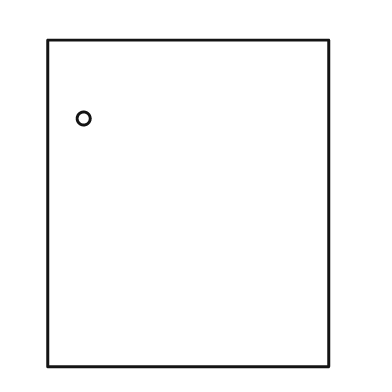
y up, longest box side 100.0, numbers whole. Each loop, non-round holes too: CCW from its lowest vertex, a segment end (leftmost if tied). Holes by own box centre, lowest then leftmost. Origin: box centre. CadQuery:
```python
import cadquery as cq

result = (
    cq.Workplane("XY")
    .moveTo(-43.0, -50.0)
    .lineTo(43.0, -50.0)
    .lineTo(43.0, 50.0)
    .lineTo(-43.0, 50.0)
    .close()
    .moveTo(-32.0, 26.0)
    .circle(2.0)
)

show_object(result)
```